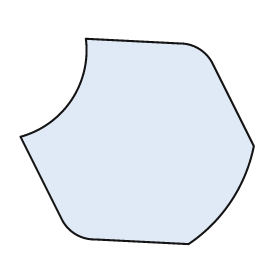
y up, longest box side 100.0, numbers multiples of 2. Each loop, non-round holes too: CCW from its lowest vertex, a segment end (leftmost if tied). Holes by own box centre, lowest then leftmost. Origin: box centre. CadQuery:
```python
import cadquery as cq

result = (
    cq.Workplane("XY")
    .moveTo(22.0, -44.0)
    .threePointArc((40.0, -26.0), (50.0, -2.0))
    .lineTo(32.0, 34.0)
    .threePointArc((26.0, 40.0), (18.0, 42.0))
    .lineTo(-22.0, 44.0)
    .threePointArc((-28.0, 18.0), (-50.0, 2.0))
    .lineTo(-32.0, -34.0)
    .threePointArc((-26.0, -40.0), (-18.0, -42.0))
    .close()
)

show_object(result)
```